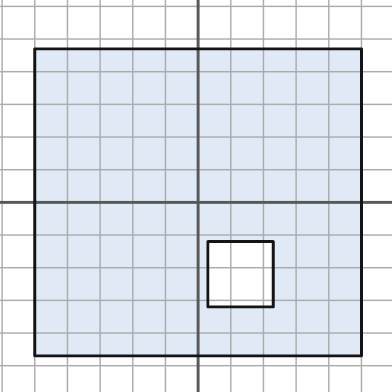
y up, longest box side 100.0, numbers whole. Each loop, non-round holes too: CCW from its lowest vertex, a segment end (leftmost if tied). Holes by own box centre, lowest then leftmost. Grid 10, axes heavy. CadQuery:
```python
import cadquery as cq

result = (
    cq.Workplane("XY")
    .moveTo(-50.0, -47.0)
    .lineTo(50.0, -47.0)
    .lineTo(50.0, 47.0)
    .lineTo(-50.0, 47.0)
    .close()
    .moveTo(3.0, -32.0)
    .lineTo(23.0, -32.0)
    .lineTo(23.0, -12.0)
    .lineTo(3.0, -12.0)
    .close()
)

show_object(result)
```